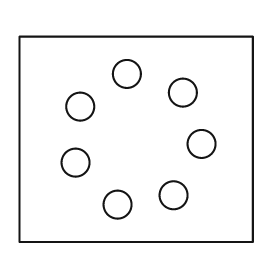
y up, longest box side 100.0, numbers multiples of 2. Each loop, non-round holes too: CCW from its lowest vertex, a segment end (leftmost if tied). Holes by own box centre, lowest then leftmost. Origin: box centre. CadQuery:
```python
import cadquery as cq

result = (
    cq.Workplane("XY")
    .moveTo(-50.0, -44.0)
    .lineTo(50.0, -44.0)
    .lineTo(50.0, 44.0)
    .lineTo(-50.0, 44.0)
    .close()
    .moveTo(-8.0, -28.0)
    .circle(6.0)
    .moveTo(16.0, -24.0)
    .circle(6.0)
    .moveTo(-26.0, -10.0)
    .circle(6.0)
    .moveTo(28.0, -2.0)
    .circle(6.0)
    .moveTo(-24.0, 14.0)
    .circle(6.0)
    .moveTo(20.0, 20.0)
    .circle(6.0)
    .moveTo(-4.0, 28.0)
    .circle(6.0)
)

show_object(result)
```